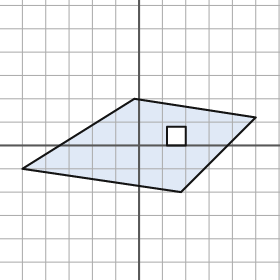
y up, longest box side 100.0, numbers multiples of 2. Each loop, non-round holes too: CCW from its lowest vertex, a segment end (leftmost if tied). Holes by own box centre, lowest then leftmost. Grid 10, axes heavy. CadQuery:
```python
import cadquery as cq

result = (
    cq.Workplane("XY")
    .moveTo(18.0, -20.0)
    .lineTo(50.0, 12.0)
    .lineTo(-2.0, 20.0)
    .lineTo(-50.0, -10.0)
    .close()
    .moveTo(12.0, 0.0)
    .lineTo(20.0, 0.0)
    .lineTo(20.0, 8.0)
    .lineTo(12.0, 8.0)
    .close()
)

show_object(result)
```